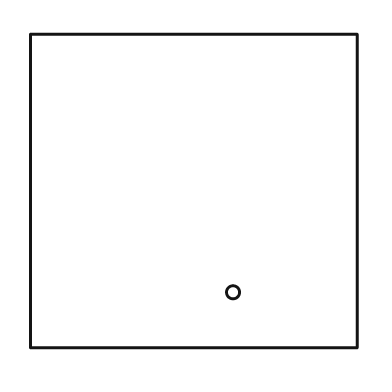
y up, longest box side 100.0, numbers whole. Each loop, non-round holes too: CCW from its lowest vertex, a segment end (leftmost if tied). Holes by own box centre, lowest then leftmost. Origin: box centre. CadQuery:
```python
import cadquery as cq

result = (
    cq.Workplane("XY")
    .moveTo(-50.0, -48.0)
    .lineTo(50.0, -48.0)
    .lineTo(50.0, 48.0)
    .lineTo(-50.0, 48.0)
    .close()
    .moveTo(12.0, -31.0)
    .circle(2.0)
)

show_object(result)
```